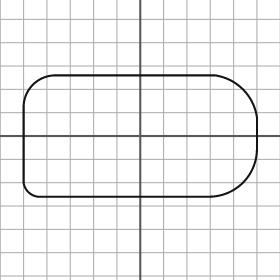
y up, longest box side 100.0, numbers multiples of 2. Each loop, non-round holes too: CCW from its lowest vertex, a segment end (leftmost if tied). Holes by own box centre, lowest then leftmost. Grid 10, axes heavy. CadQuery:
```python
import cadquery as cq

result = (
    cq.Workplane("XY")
    .moveTo(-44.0, -26.0)
    .lineTo(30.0, -26.0)
    .threePointArc((44.0, -20.0), (50.0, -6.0))
    .lineTo(50.0, 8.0)
    .threePointArc((44.0, 20.0), (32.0, 26.0))
    .lineTo(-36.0, 26.0)
    .threePointArc((-46.0, 22.0), (-50.0, 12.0))
    .lineTo(-50.0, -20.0)
    .threePointArc((-48.0, -24.0), (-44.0, -26.0))
    .close()
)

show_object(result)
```